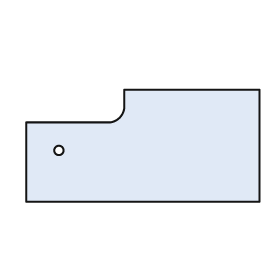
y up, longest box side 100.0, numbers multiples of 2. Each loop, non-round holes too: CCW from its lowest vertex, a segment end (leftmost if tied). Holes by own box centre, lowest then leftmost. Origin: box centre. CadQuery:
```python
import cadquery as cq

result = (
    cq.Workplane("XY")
    .moveTo(-50.0, -24.0)
    .lineTo(50.0, -24.0)
    .lineTo(50.0, 24.0)
    .lineTo(-8.0, 24.0)
    .lineTo(-8.0, 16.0)
    .threePointArc((-10.0, 12.0), (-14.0, 10.0))
    .lineTo(-50.0, 10.0)
    .close()
    .moveTo(-36.0, -2.0)
    .circle(2.0)
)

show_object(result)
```